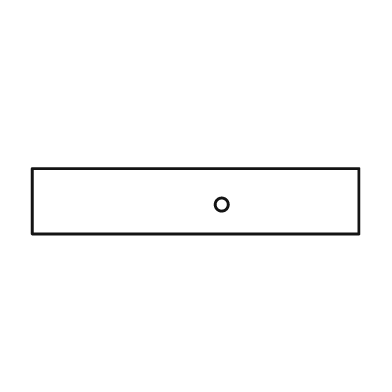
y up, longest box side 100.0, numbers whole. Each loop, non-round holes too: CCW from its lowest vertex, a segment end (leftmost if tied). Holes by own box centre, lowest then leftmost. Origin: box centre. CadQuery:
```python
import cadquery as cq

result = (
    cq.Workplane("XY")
    .moveTo(-50.0, -10.0)
    .lineTo(50.0, -10.0)
    .lineTo(50.0, 10.0)
    .lineTo(-50.0, 10.0)
    .close()
    .moveTo(8.0, -1.0)
    .circle(2.0)
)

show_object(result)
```